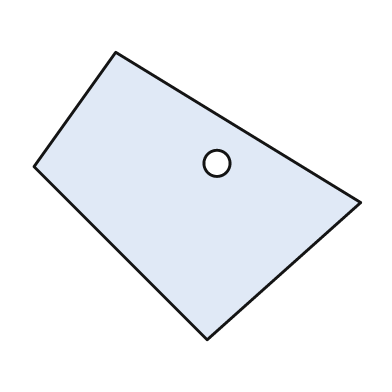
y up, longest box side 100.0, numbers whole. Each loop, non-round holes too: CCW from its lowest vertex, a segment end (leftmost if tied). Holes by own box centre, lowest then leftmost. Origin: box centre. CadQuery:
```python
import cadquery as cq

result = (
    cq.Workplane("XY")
    .moveTo(3.0, -44.0)
    .lineTo(50.0, -2.0)
    .lineTo(-25.0, 44.0)
    .lineTo(-50.0, 9.0)
    .close()
    .moveTo(6.0, 10.0)
    .circle(4.0)
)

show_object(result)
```